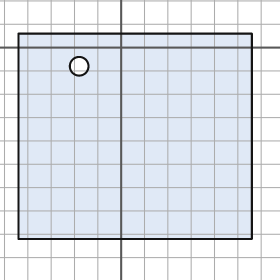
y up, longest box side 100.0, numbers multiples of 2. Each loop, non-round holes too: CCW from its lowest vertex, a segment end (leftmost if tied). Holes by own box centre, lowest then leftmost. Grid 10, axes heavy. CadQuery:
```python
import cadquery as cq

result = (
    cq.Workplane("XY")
    .moveTo(-44.0, -82.0)
    .lineTo(56.0, -82.0)
    .lineTo(56.0, 6.0)
    .lineTo(-44.0, 6.0)
    .close()
    .moveTo(-18.0, -8.0)
    .circle(4.0)
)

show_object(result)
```